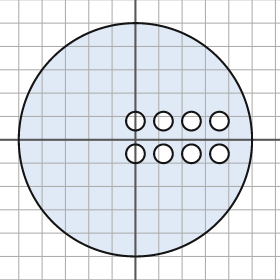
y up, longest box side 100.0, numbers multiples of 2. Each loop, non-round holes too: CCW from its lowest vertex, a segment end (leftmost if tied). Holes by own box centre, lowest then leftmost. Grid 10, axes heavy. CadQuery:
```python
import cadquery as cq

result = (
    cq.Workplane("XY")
    .moveTo(0.0, 0.0)
    .circle(50.0)
    .moveTo(0.0, -6.0)
    .circle(4.0)
    .moveTo(12.0, -6.0)
    .circle(4.0)
    .moveTo(24.0, -6.0)
    .circle(4.0)
    .moveTo(36.0, -6.0)
    .circle(4.0)
    .moveTo(0.0, 8.0)
    .circle(4.0)
    .moveTo(12.0, 8.0)
    .circle(4.0)
    .moveTo(24.0, 8.0)
    .circle(4.0)
    .moveTo(36.0, 8.0)
    .circle(4.0)
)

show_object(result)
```